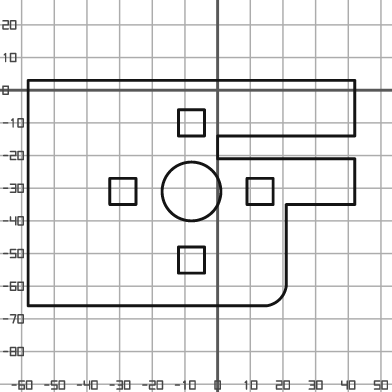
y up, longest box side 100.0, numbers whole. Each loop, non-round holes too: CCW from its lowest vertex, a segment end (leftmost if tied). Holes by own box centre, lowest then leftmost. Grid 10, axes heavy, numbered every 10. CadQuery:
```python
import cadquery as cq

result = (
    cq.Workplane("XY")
    .moveTo(-58.0, -66.0)
    .lineTo(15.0, -66.0)
    .threePointArc((19.0, -64.0), (21.0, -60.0))
    .lineTo(21.0, -35.0)
    .lineTo(42.0, -35.0)
    .lineTo(42.0, -21.0)
    .lineTo(0.0, -21.0)
    .lineTo(0.0, -14.0)
    .lineTo(42.0, -14.0)
    .lineTo(42.0, 3.0)
    .lineTo(-58.0, 3.0)
    .close()
    .moveTo(-12.0, -56.0)
    .lineTo(-4.0, -56.0)
    .lineTo(-4.0, -48.0)
    .lineTo(-12.0, -48.0)
    .close()
    .moveTo(-33.0, -35.0)
    .lineTo(-25.0, -35.0)
    .lineTo(-25.0, -27.0)
    .lineTo(-33.0, -27.0)
    .close()
    .moveTo(-8.0, -31.0)
    .circle(9.0)
    .moveTo(9.0, -35.0)
    .lineTo(17.0, -35.0)
    .lineTo(17.0, -27.0)
    .lineTo(9.0, -27.0)
    .close()
    .moveTo(-12.0, -14.0)
    .lineTo(-4.0, -14.0)
    .lineTo(-4.0, -6.0)
    .lineTo(-12.0, -6.0)
    .close()
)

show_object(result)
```